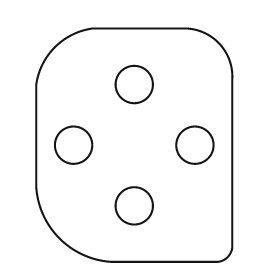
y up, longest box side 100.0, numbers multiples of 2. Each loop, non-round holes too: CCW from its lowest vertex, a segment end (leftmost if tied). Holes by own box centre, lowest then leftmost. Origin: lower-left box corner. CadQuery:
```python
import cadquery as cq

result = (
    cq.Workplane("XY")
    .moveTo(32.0, 0.0)
    .lineTo(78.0, 0.0)
    .threePointArc((82.0, 2.0), (84.0, 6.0))
    .lineTo(84.0, 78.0)
    .threePointArc((78.0, 94.0), (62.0, 100.0))
    .lineTo(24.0, 100.0)
    .threePointArc((8.0, 92.0), (0.0, 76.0))
    .lineTo(0.0, 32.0)
    .threePointArc((10.0, 10.0), (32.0, 0.0))
    .close()
    .moveTo(42.0, 24.0)
    .circle(8.0)
    .moveTo(16.0, 50.0)
    .circle(8.0)
    .moveTo(68.0, 50.0)
    .circle(8.0)
    .moveTo(42.0, 76.0)
    .circle(8.0)
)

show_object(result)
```